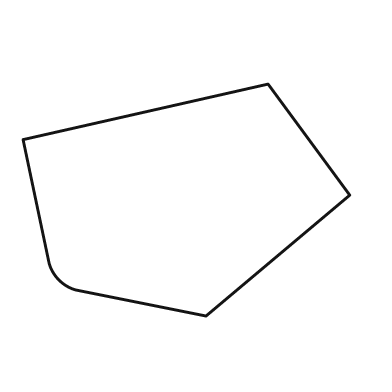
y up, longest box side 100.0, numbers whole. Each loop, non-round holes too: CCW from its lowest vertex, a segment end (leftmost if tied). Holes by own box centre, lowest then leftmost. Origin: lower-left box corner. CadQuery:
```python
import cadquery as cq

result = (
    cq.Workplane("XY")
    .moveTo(56.0, 0.0)
    .lineTo(100.0, 37.0)
    .lineTo(75.0, 71.0)
    .lineTo(0.0, 54.0)
    .lineTo(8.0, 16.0)
    .threePointArc((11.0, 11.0), (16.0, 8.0))
    .close()
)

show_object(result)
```